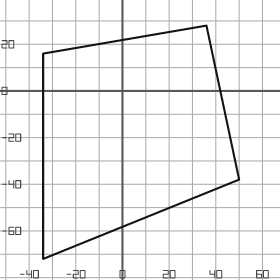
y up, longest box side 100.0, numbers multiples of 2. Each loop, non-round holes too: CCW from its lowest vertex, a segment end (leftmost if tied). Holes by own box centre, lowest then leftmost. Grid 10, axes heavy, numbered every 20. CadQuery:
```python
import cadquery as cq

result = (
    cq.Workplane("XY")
    .moveTo(-34.0, -72.0)
    .lineTo(50.0, -38.0)
    .lineTo(36.0, 28.0)
    .lineTo(-34.0, 16.0)
    .close()
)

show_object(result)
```